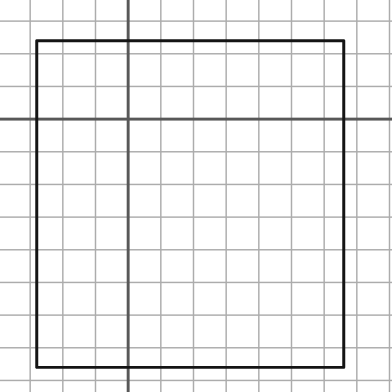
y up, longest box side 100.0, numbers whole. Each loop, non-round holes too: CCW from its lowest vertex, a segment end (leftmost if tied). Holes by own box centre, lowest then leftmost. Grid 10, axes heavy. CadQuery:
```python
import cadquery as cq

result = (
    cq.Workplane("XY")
    .moveTo(-28.0, -76.0)
    .lineTo(66.0, -76.0)
    .lineTo(66.0, 24.0)
    .lineTo(-28.0, 24.0)
    .close()
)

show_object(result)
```